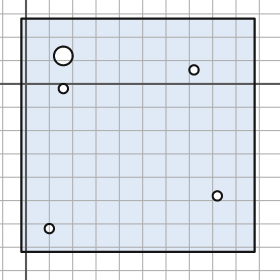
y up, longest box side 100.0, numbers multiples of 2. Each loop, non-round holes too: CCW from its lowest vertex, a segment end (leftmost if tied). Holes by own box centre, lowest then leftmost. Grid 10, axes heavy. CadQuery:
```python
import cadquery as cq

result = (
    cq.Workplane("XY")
    .moveTo(-2.0, -72.0)
    .lineTo(98.0, -72.0)
    .lineTo(98.0, 28.0)
    .lineTo(-2.0, 28.0)
    .close()
    .moveTo(10.0, -62.0)
    .circle(2.0)
    .moveTo(82.0, -48.0)
    .circle(2.0)
    .moveTo(16.0, -2.0)
    .circle(2.0)
    .moveTo(72.0, 6.0)
    .circle(2.0)
    .moveTo(16.0, 12.0)
    .circle(4.0)
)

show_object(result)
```